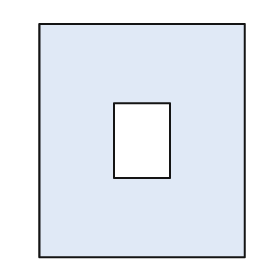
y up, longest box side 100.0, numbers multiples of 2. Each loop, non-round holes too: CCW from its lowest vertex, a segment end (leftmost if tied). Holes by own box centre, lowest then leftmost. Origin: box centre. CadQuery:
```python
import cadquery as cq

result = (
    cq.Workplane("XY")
    .moveTo(-44.0, -50.0)
    .lineTo(44.0, -50.0)
    .lineTo(44.0, 50.0)
    .lineTo(-44.0, 50.0)
    .close()
    .moveTo(-12.0, -16.0)
    .lineTo(12.0, -16.0)
    .lineTo(12.0, 16.0)
    .lineTo(-12.0, 16.0)
    .close()
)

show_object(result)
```